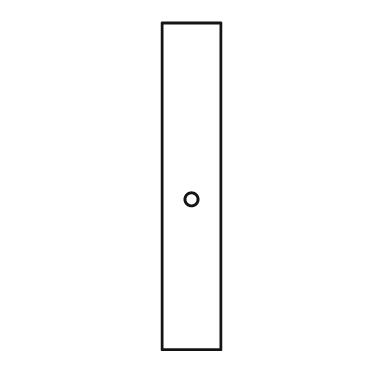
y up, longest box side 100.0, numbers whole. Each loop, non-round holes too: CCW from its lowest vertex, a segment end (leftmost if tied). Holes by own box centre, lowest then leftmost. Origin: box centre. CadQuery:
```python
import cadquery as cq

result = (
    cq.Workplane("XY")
    .moveTo(-9.0, -50.0)
    .lineTo(9.0, -50.0)
    .lineTo(9.0, 50.0)
    .lineTo(-9.0, 50.0)
    .close()
    .moveTo(0.0, -4.0)
    .circle(2.0)
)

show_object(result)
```